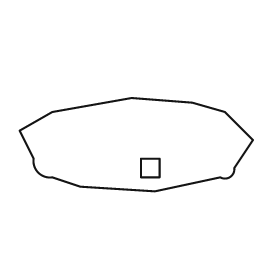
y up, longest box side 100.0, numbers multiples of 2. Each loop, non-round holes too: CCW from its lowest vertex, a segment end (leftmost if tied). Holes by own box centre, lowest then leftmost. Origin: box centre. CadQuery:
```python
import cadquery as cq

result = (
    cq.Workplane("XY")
    .moveTo(8.0, -20.0)
    .lineTo(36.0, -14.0)
    .threePointArc((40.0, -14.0), (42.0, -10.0))
    .lineTo(50.0, 2.0)
    .lineTo(38.0, 14.0)
    .lineTo(24.0, 18.0)
    .lineTo(-2.0, 20.0)
    .lineTo(-36.0, 14.0)
    .lineTo(-50.0, 6.0)
    .lineTo(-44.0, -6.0)
    .threePointArc((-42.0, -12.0), (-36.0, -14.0))
    .lineTo(-24.0, -18.0)
    .close()
    .moveTo(2.0, -14.0)
    .lineTo(10.0, -14.0)
    .lineTo(10.0, -6.0)
    .lineTo(2.0, -6.0)
    .close()
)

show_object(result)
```